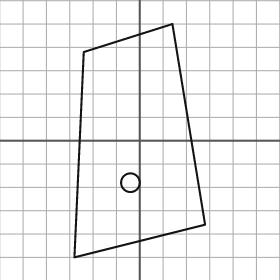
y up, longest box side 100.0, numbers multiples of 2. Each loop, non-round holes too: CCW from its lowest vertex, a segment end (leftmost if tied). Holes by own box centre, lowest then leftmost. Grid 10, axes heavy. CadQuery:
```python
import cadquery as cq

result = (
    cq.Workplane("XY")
    .moveTo(-28.0, -50.0)
    .lineTo(28.0, -36.0)
    .lineTo(14.0, 50.0)
    .lineTo(-24.0, 38.0)
    .close()
    .moveTo(-4.0, -18.0)
    .circle(4.0)
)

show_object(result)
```